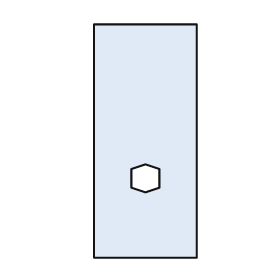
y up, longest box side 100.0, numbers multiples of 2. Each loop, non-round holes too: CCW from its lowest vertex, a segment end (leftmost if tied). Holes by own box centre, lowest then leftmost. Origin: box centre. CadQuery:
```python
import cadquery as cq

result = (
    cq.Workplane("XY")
    .moveTo(-22.0, -50.0)
    .lineTo(22.0, -50.0)
    .lineTo(22.0, 50.0)
    .lineTo(-22.0, 50.0)
    .close()
    .moveTo(0.0, -22.0)
    .lineTo(6.0, -20.0)
    .lineTo(6.0, -12.0)
    .lineTo(0.0, -10.0)
    .lineTo(-6.0, -12.0)
    .lineTo(-6.0, -20.0)
    .close()
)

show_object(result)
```